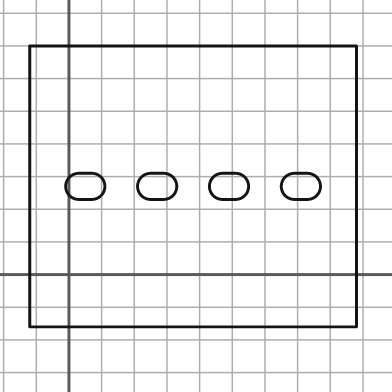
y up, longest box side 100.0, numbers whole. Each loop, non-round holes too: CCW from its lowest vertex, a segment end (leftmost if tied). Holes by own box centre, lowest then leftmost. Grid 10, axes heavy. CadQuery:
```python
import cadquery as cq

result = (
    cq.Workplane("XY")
    .moveTo(-12.0, -16.0)
    .lineTo(88.0, -16.0)
    .lineTo(88.0, 70.0)
    .lineTo(-12.0, 70.0)
    .close()
    .moveTo(3.0, 23.0)
    .lineTo(7.0, 23.0)
    .threePointArc((11.0, 27.0), (7.0, 31.0))
    .lineTo(3.0, 31.0)
    .threePointArc((-1.0, 27.0), (3.0, 23.0))
    .close()
    .moveTo(25.0, 23.0)
    .lineTo(29.0, 23.0)
    .threePointArc((33.0, 27.0), (29.0, 31.0))
    .lineTo(25.0, 31.0)
    .threePointArc((21.0, 27.0), (25.0, 23.0))
    .close()
    .moveTo(47.0, 23.0)
    .lineTo(51.0, 23.0)
    .threePointArc((55.0, 27.0), (51.0, 31.0))
    .lineTo(47.0, 31.0)
    .threePointArc((43.0, 27.0), (47.0, 23.0))
    .close()
    .moveTo(69.0, 23.0)
    .lineTo(73.0, 23.0)
    .threePointArc((77.0, 27.0), (73.0, 31.0))
    .lineTo(69.0, 31.0)
    .threePointArc((65.0, 27.0), (69.0, 23.0))
    .close()
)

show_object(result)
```